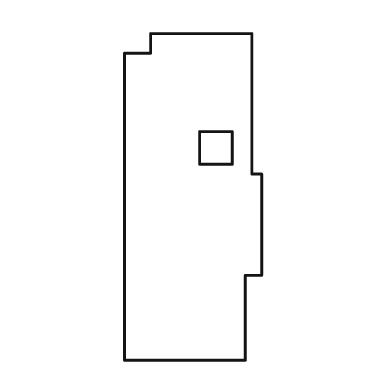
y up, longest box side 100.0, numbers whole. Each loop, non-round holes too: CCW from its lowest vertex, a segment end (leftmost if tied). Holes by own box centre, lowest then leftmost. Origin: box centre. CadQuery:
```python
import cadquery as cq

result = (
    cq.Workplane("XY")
    .moveTo(-21.0, -50.0)
    .lineTo(16.0, -50.0)
    .lineTo(16.0, -24.0)
    .lineTo(21.0, -24.0)
    .lineTo(21.0, 7.0)
    .lineTo(18.0, 7.0)
    .lineTo(18.0, 50.0)
    .lineTo(-13.0, 50.0)
    .lineTo(-13.0, 44.0)
    .lineTo(-21.0, 44.0)
    .close()
    .moveTo(2.0, 10.0)
    .lineTo(12.0, 10.0)
    .lineTo(12.0, 20.0)
    .lineTo(2.0, 20.0)
    .close()
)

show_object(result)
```